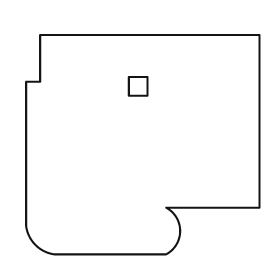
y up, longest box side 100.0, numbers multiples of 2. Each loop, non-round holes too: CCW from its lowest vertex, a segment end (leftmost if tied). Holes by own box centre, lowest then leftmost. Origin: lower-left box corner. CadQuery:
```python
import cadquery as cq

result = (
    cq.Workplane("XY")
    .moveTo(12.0, 0.0)
    .lineTo(60.0, 0.0)
    .threePointArc((66.0, 10.0), (60.0, 20.0))
    .lineTo(100.0, 20.0)
    .lineTo(100.0, 94.0)
    .lineTo(6.0, 94.0)
    .lineTo(6.0, 74.0)
    .lineTo(0.0, 74.0)
    .lineTo(0.0, 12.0)
    .threePointArc((4.0, 4.0), (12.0, 0.0))
    .close()
    .moveTo(44.0, 68.0)
    .lineTo(52.0, 68.0)
    .lineTo(52.0, 76.0)
    .lineTo(44.0, 76.0)
    .close()
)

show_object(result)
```